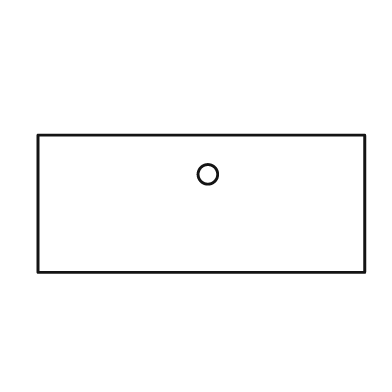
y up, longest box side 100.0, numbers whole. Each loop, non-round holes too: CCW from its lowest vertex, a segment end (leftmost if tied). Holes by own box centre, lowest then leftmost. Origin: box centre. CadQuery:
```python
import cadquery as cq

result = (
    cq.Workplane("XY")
    .moveTo(-50.0, -21.0)
    .lineTo(50.0, -21.0)
    .lineTo(50.0, 21.0)
    .lineTo(-50.0, 21.0)
    .close()
    .moveTo(2.0, 9.0)
    .circle(3.0)
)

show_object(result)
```